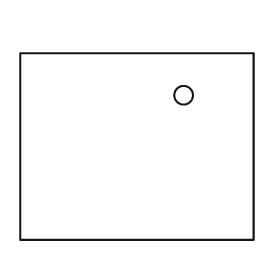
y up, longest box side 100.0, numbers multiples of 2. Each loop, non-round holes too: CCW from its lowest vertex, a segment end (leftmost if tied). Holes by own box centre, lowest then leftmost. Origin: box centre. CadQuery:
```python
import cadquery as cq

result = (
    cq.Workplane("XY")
    .moveTo(-50.0, -40.0)
    .lineTo(50.0, -40.0)
    .lineTo(50.0, 40.0)
    .lineTo(-50.0, 40.0)
    .close()
    .moveTo(20.0, 22.0)
    .circle(4.0)
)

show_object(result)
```